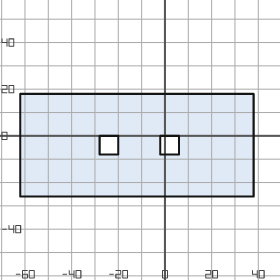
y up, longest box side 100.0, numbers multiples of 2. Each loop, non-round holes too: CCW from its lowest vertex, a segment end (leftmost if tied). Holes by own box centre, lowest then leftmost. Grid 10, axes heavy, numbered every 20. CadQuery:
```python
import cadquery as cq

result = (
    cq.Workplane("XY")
    .moveTo(-62.0, -26.0)
    .lineTo(38.0, -26.0)
    .lineTo(38.0, 18.0)
    .lineTo(-62.0, 18.0)
    .close()
    .moveTo(-28.0, -8.0)
    .lineTo(-20.0, -8.0)
    .lineTo(-20.0, 0.0)
    .lineTo(-28.0, 0.0)
    .close()
    .moveTo(-2.0, -8.0)
    .lineTo(6.0, -8.0)
    .lineTo(6.0, 0.0)
    .lineTo(-2.0, 0.0)
    .close()
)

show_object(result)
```